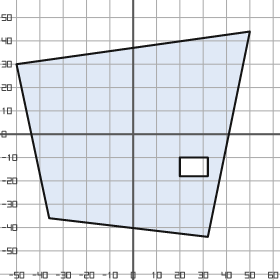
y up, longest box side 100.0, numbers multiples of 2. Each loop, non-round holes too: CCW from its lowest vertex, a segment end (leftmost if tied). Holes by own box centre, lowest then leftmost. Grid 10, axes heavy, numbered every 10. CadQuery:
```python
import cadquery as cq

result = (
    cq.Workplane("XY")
    .moveTo(32.0, -44.0)
    .lineTo(50.0, 44.0)
    .lineTo(-50.0, 30.0)
    .lineTo(-36.0, -36.0)
    .close()
    .moveTo(20.0, -18.0)
    .lineTo(32.0, -18.0)
    .lineTo(32.0, -10.0)
    .lineTo(20.0, -10.0)
    .close()
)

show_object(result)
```